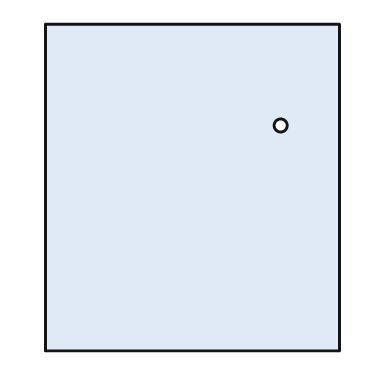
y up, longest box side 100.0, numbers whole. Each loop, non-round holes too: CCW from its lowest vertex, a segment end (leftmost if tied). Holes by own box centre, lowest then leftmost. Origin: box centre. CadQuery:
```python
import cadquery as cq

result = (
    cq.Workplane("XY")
    .moveTo(-45.0, -50.0)
    .lineTo(45.0, -50.0)
    .lineTo(45.0, 50.0)
    .lineTo(-45.0, 50.0)
    .close()
    .moveTo(27.0, 19.0)
    .circle(2.0)
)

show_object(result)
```